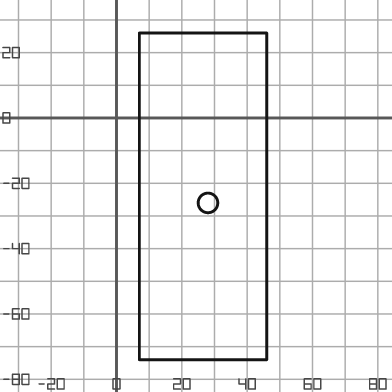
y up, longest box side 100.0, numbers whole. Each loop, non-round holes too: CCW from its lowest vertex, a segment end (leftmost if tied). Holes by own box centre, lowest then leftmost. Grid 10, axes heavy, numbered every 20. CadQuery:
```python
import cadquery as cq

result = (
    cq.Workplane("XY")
    .moveTo(7.0, -74.0)
    .lineTo(46.0, -74.0)
    .lineTo(46.0, 26.0)
    .lineTo(7.0, 26.0)
    .close()
    .moveTo(28.0, -26.0)
    .circle(3.0)
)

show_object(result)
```